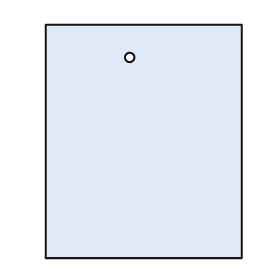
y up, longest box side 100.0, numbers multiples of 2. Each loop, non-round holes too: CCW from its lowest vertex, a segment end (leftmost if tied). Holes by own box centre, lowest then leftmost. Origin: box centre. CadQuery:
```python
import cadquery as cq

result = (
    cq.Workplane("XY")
    .moveTo(-42.0, -50.0)
    .lineTo(42.0, -50.0)
    .lineTo(42.0, 50.0)
    .lineTo(-42.0, 50.0)
    .close()
    .moveTo(-6.0, 36.0)
    .circle(2.0)
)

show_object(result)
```